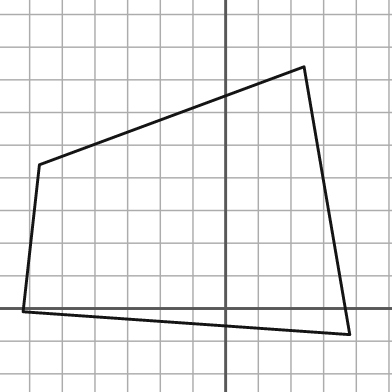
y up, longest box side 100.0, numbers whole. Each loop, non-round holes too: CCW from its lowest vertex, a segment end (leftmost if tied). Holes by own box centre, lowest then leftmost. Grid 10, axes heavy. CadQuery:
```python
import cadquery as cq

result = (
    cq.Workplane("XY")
    .moveTo(38.0, -8.0)
    .lineTo(24.0, 74.0)
    .lineTo(-57.0, 44.0)
    .lineTo(-62.0, -1.0)
    .close()
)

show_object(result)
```